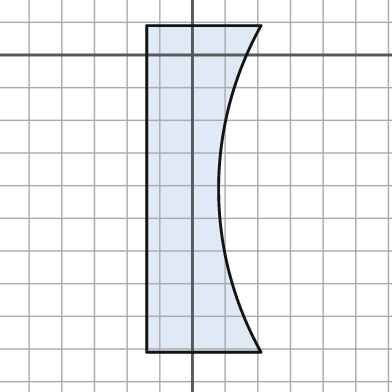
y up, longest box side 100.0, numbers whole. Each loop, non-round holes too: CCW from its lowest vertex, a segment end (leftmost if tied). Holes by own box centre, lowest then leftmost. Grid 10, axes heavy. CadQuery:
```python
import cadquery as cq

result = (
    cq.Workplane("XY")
    .moveTo(-14.0, -91.0)
    .lineTo(21.0, -91.0)
    .threePointArc((8.0, -41.0), (21.0, 9.0))
    .lineTo(-14.0, 9.0)
    .close()
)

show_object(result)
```